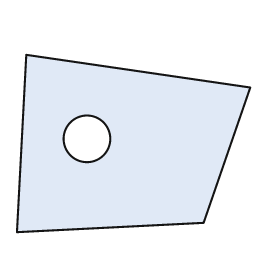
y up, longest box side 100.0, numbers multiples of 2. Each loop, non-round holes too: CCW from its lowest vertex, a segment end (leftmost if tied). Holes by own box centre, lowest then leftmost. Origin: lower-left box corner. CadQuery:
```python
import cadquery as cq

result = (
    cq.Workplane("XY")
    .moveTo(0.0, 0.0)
    .lineTo(80.0, 4.0)
    .lineTo(100.0, 62.0)
    .lineTo(4.0, 76.0)
    .close()
    .moveTo(30.0, 40.0)
    .circle(10.0)
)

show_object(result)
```